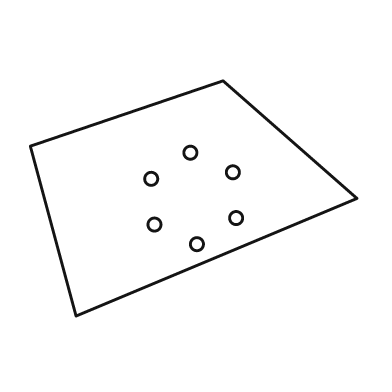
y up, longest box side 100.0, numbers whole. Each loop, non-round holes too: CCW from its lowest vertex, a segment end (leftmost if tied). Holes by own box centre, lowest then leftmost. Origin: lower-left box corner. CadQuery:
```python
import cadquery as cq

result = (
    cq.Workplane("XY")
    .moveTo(14.0, 0.0)
    .lineTo(100.0, 36.0)
    .lineTo(59.0, 72.0)
    .lineTo(0.0, 52.0)
    .close()
    .moveTo(51.0, 22.0)
    .circle(2.0)
    .moveTo(38.0, 28.0)
    .circle(2.0)
    .moveTo(63.0, 30.0)
    .circle(2.0)
    .moveTo(37.0, 42.0)
    .circle(2.0)
    .moveTo(62.0, 44.0)
    .circle(2.0)
    .moveTo(49.0, 50.0)
    .circle(2.0)
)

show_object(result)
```